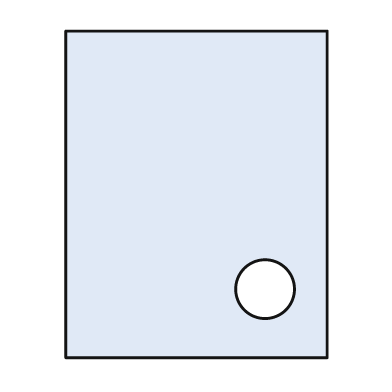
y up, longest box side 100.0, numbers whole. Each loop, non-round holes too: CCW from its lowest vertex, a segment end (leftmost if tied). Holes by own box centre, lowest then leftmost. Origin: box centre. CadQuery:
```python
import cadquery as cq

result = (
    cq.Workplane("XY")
    .moveTo(-40.0, -50.0)
    .lineTo(40.0, -50.0)
    .lineTo(40.0, 50.0)
    .lineTo(-40.0, 50.0)
    .close()
    .moveTo(21.0, -29.0)
    .circle(9.0)
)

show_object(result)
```